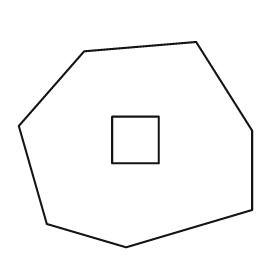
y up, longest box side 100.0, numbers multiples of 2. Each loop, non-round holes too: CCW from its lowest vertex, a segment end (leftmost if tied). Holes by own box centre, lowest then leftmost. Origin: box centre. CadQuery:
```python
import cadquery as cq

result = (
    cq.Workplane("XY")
    .moveTo(-4.0, -44.0)
    .lineTo(50.0, -28.0)
    .lineTo(50.0, 6.0)
    .lineTo(26.0, 44.0)
    .lineTo(-22.0, 40.0)
    .lineTo(-50.0, 8.0)
    .lineTo(-38.0, -34.0)
    .close()
    .moveTo(-10.0, -8.0)
    .lineTo(10.0, -8.0)
    .lineTo(10.0, 12.0)
    .lineTo(-10.0, 12.0)
    .close()
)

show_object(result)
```